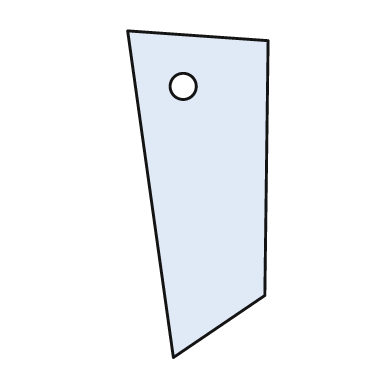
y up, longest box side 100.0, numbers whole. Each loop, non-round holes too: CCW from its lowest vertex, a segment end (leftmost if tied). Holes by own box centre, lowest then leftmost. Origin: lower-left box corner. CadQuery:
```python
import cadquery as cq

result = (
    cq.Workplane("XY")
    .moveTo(14.0, 0.0)
    .lineTo(42.0, 19.0)
    .lineTo(43.0, 97.0)
    .lineTo(0.0, 100.0)
    .close()
    .moveTo(17.0, 83.0)
    .circle(4.0)
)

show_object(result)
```